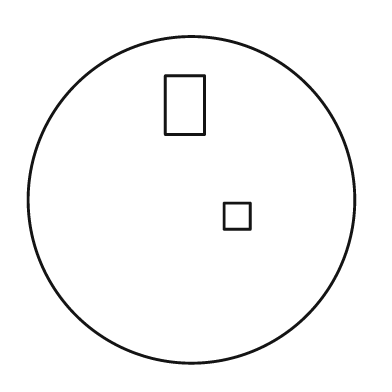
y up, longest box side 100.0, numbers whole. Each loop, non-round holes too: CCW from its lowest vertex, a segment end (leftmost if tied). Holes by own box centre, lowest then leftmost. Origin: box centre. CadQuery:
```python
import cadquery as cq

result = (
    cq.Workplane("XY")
    .moveTo(0.0, 0.0)
    .circle(50.0)
    .moveTo(10.0, -9.0)
    .lineTo(18.0, -9.0)
    .lineTo(18.0, -1.0)
    .lineTo(10.0, -1.0)
    .close()
    .moveTo(-8.0, 20.0)
    .lineTo(4.0, 20.0)
    .lineTo(4.0, 38.0)
    .lineTo(-8.0, 38.0)
    .close()
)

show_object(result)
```